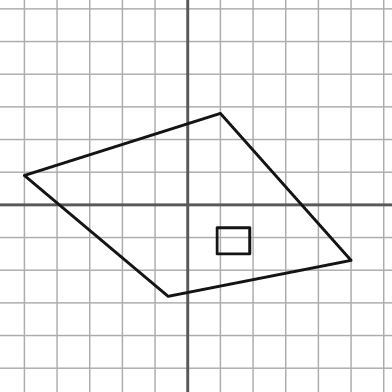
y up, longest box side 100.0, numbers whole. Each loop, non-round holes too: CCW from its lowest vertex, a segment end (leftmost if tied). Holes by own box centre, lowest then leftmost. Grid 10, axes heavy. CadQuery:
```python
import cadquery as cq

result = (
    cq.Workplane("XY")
    .moveTo(-6.0, -28.0)
    .lineTo(50.0, -17.0)
    .lineTo(10.0, 28.0)
    .lineTo(-50.0, 9.0)
    .close()
    .moveTo(9.0, -15.0)
    .lineTo(19.0, -15.0)
    .lineTo(19.0, -7.0)
    .lineTo(9.0, -7.0)
    .close()
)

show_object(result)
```